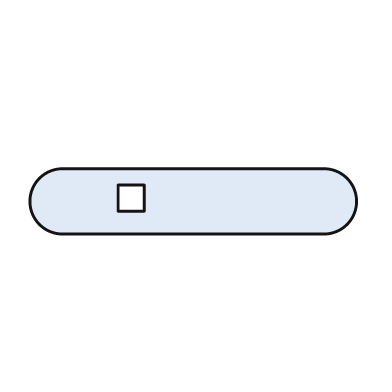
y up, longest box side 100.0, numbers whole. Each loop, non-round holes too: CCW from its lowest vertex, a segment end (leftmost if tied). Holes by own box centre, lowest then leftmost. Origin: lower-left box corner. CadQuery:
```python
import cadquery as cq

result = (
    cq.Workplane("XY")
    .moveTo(10.0, 0.0)
    .lineTo(90.0, 0.0)
    .threePointArc((100.0, 10.0), (90.0, 20.0))
    .lineTo(10.0, 20.0)
    .threePointArc((0.0, 10.0), (10.0, 0.0))
    .close()
    .moveTo(27.0, 7.0)
    .lineTo(35.0, 7.0)
    .lineTo(35.0, 15.0)
    .lineTo(27.0, 15.0)
    .close()
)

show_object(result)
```